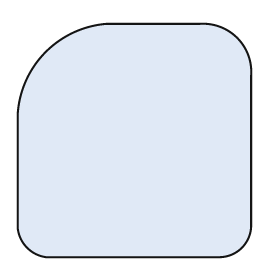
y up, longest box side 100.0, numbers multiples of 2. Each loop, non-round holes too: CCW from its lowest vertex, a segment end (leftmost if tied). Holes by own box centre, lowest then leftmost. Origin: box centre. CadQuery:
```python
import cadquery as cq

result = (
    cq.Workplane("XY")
    .moveTo(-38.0, -50.0)
    .lineTo(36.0, -50.0)
    .threePointArc((46.0, -46.0), (50.0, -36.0))
    .lineTo(50.0, 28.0)
    .threePointArc((44.0, 44.0), (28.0, 50.0))
    .lineTo(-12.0, 50.0)
    .threePointArc((-38.0, 38.0), (-50.0, 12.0))
    .lineTo(-50.0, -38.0)
    .threePointArc((-46.0, -46.0), (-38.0, -50.0))
    .close()
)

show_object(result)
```